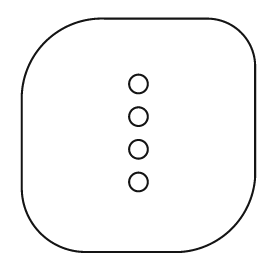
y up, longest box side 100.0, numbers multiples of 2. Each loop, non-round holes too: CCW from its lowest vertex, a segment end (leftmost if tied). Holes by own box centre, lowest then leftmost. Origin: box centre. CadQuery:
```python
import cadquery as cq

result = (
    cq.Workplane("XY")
    .moveTo(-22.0, -50.0)
    .lineTo(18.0, -50.0)
    .threePointArc((40.0, -40.0), (50.0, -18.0))
    .lineTo(50.0, 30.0)
    .threePointArc((44.0, 44.0), (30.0, 50.0))
    .lineTo(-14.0, 50.0)
    .threePointArc((-40.0, 40.0), (-50.0, 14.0))
    .lineTo(-50.0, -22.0)
    .threePointArc((-42.0, -42.0), (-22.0, -50.0))
    .close()
    .moveTo(0.0, -20.0)
    .circle(4.0)
    .moveTo(0.0, -6.0)
    .circle(4.0)
    .moveTo(0.0, 8.0)
    .circle(4.0)
    .moveTo(0.0, 22.0)
    .circle(4.0)
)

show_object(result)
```